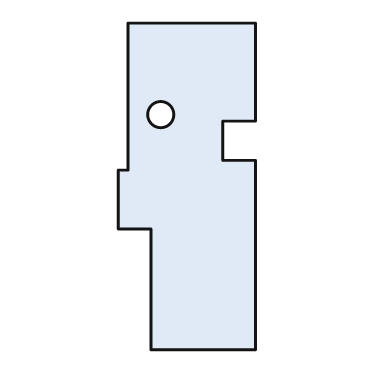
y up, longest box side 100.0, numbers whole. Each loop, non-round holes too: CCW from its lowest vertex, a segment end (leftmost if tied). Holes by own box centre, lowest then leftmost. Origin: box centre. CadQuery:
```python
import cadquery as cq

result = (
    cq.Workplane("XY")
    .moveTo(-11.0, -50.0)
    .lineTo(21.0, -50.0)
    .lineTo(21.0, 8.0)
    .lineTo(11.0, 8.0)
    .lineTo(11.0, 20.0)
    .lineTo(21.0, 20.0)
    .lineTo(21.0, 50.0)
    .lineTo(-18.0, 50.0)
    .lineTo(-18.0, 5.0)
    .lineTo(-21.0, 5.0)
    .lineTo(-21.0, -13.0)
    .lineTo(-11.0, -13.0)
    .close()
    .moveTo(-8.0, 22.0)
    .circle(4.0)
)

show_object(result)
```